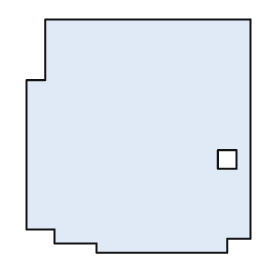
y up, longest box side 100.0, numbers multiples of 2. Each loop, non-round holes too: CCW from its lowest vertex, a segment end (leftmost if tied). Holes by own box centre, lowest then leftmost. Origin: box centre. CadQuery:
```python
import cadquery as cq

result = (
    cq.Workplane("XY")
    .moveTo(-18.0, -50.0)
    .lineTo(38.0, -50.0)
    .lineTo(38.0, -44.0)
    .lineTo(48.0, -44.0)
    .lineTo(48.0, 50.0)
    .lineTo(-40.0, 50.0)
    .lineTo(-40.0, 24.0)
    .lineTo(-48.0, 24.0)
    .lineTo(-48.0, -40.0)
    .lineTo(-36.0, -40.0)
    .lineTo(-36.0, -46.0)
    .lineTo(-18.0, -46.0)
    .close()
    .moveTo(34.0, -14.0)
    .lineTo(42.0, -14.0)
    .lineTo(42.0, -6.0)
    .lineTo(34.0, -6.0)
    .close()
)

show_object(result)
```